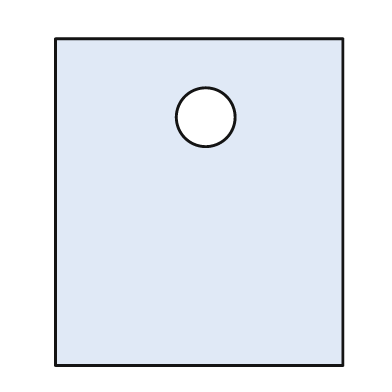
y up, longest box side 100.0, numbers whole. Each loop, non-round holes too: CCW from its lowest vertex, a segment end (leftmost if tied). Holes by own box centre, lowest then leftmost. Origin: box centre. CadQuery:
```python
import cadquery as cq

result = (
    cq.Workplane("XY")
    .moveTo(-44.0, -50.0)
    .lineTo(44.0, -50.0)
    .lineTo(44.0, 50.0)
    .lineTo(-44.0, 50.0)
    .close()
    .moveTo(2.0, 26.0)
    .circle(9.0)
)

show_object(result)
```